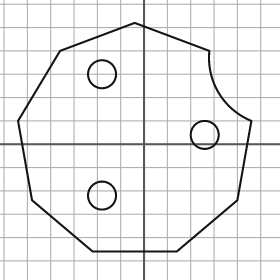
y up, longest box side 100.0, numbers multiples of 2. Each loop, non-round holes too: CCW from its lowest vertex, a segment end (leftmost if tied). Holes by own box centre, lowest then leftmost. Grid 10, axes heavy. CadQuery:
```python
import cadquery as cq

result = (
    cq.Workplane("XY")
    .moveTo(-22.0, -46.0)
    .lineTo(14.0, -46.0)
    .lineTo(40.0, -24.0)
    .lineTo(46.0, 10.0)
    .threePointArc((32.0, 22.0), (28.0, 40.0))
    .lineTo(-4.0, 52.0)
    .lineTo(-36.0, 40.0)
    .lineTo(-54.0, 10.0)
    .lineTo(-48.0, -24.0)
    .close()
    .moveTo(-18.0, -22.0)
    .circle(6.0)
    .moveTo(26.0, 4.0)
    .circle(6.0)
    .moveTo(-18.0, 30.0)
    .circle(6.0)
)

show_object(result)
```